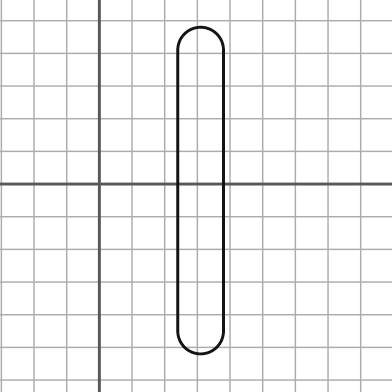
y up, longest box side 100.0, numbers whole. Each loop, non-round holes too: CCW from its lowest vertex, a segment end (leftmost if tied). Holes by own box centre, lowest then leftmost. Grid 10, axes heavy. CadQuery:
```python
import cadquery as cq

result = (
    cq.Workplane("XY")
    .moveTo(24.0, -45.0)
    .threePointArc((31.0, -52.0), (38.0, -45.0))
    .lineTo(38.0, 41.0)
    .threePointArc((31.0, 48.0), (24.0, 41.0))
    .close()
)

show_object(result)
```